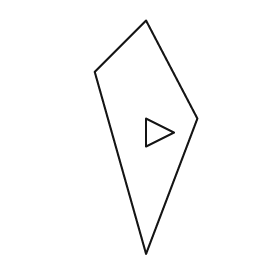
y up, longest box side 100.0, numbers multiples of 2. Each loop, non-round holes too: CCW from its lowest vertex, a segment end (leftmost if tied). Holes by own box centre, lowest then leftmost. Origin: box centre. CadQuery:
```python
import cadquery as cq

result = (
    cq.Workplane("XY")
    .moveTo(0.0, -50.0)
    .lineTo(22.0, 8.0)
    .lineTo(0.0, 50.0)
    .lineTo(-22.0, 28.0)
    .close()
    .moveTo(0.0, -4.0)
    .lineTo(12.0, 2.0)
    .lineTo(0.0, 8.0)
    .close()
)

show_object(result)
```